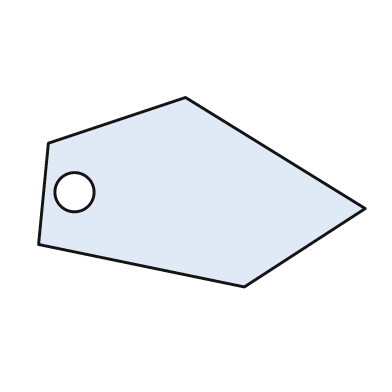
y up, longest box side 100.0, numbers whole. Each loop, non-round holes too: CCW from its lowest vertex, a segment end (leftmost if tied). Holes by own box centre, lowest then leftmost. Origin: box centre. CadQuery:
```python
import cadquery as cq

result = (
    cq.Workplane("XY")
    .moveTo(13.0, -29.0)
    .lineTo(50.0, -5.0)
    .lineTo(-5.0, 29.0)
    .lineTo(-47.0, 15.0)
    .lineTo(-50.0, -16.0)
    .close()
    .moveTo(-39.0, 0.0)
    .circle(6.0)
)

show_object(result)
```